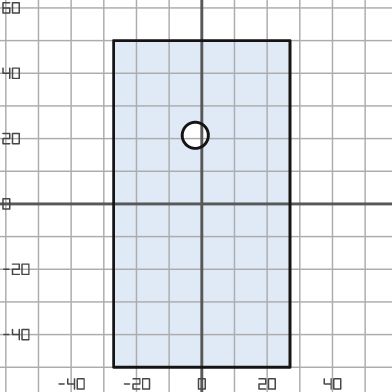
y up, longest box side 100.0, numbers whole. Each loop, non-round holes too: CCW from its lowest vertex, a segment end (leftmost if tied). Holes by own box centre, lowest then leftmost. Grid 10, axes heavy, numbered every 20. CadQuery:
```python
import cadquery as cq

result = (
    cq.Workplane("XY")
    .moveTo(-27.0, -50.0)
    .lineTo(27.0, -50.0)
    .lineTo(27.0, 50.0)
    .lineTo(-27.0, 50.0)
    .close()
    .moveTo(-2.0, 21.0)
    .circle(4.0)
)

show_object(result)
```